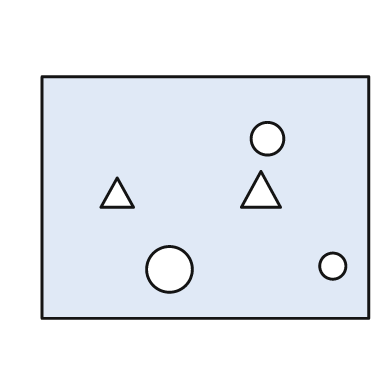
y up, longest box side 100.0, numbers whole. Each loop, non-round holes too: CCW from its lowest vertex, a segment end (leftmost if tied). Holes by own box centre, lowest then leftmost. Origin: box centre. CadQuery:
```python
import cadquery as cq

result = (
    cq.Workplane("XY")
    .moveTo(-50.0, -37.0)
    .lineTo(50.0, -37.0)
    .lineTo(50.0, 37.0)
    .lineTo(-50.0, 37.0)
    .close()
    .moveTo(-11.0, -22.0)
    .circle(7.0)
    .moveTo(39.0, -21.0)
    .circle(4.0)
    .moveTo(-32.0, -3.0)
    .lineTo(-22.0, -3.0)
    .lineTo(-27.0, 6.0)
    .close()
    .moveTo(11.0, -3.0)
    .lineTo(23.0, -3.0)
    .lineTo(17.0, 8.0)
    .close()
    .moveTo(19.0, 18.0)
    .circle(5.0)
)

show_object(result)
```